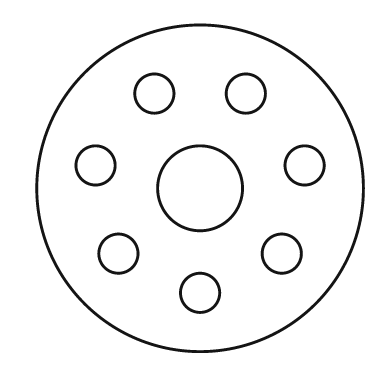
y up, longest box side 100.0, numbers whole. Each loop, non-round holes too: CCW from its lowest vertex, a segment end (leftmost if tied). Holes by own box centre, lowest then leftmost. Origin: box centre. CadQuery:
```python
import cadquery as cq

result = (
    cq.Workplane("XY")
    .moveTo(0.0, 0.0)
    .circle(50.0)
    .moveTo(0.0, -32.0)
    .circle(6.0)
    .moveTo(-25.0, -20.0)
    .circle(6.0)
    .moveTo(25.0, -20.0)
    .circle(6.0)
    .moveTo(0.0, 0.0)
    .circle(13.0)
    .moveTo(-32.0, 7.0)
    .circle(6.0)
    .moveTo(32.0, 7.0)
    .circle(6.0)
    .moveTo(-14.0, 29.0)
    .circle(6.0)
    .moveTo(14.0, 29.0)
    .circle(6.0)
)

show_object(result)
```